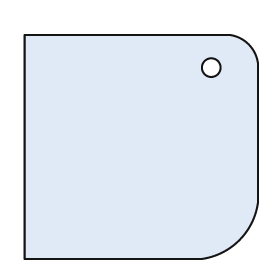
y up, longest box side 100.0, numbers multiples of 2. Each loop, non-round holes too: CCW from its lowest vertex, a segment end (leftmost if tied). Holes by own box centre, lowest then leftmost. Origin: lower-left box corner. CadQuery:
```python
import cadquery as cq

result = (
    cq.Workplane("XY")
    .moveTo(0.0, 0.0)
    .lineTo(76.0, 0.0)
    .threePointArc((92.0, 8.0), (100.0, 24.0))
    .lineTo(100.0, 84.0)
    .threePointArc((96.0, 92.0), (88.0, 96.0))
    .lineTo(0.0, 96.0)
    .close()
    .moveTo(80.0, 82.0)
    .circle(4.0)
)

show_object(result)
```